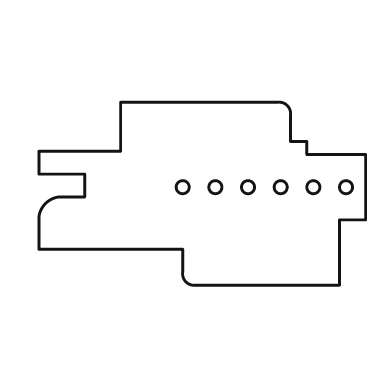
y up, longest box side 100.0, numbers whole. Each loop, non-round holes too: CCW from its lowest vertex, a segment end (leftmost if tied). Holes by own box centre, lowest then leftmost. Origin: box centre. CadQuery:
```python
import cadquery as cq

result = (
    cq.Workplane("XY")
    .moveTo(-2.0, -28.0)
    .lineTo(42.0, -28.0)
    .lineTo(42.0, -8.0)
    .lineTo(50.0, -8.0)
    .lineTo(50.0, 12.0)
    .lineTo(32.0, 12.0)
    .lineTo(32.0, 16.0)
    .lineTo(27.0, 16.0)
    .lineTo(27.0, 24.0)
    .threePointArc((26.0, 27.0), (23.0, 28.0))
    .lineTo(-25.0, 28.0)
    .lineTo(-25.0, 13.0)
    .lineTo(-50.0, 13.0)
    .lineTo(-50.0, 6.0)
    .lineTo(-36.0, 6.0)
    .lineTo(-36.0, -1.0)
    .lineTo(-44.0, -1.0)
    .threePointArc((-48.0, -3.0), (-50.0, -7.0))
    .lineTo(-50.0, -17.0)
    .lineTo(-6.0, -17.0)
    .lineTo(-6.0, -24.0)
    .threePointArc((-5.0, -27.0), (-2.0, -28.0))
    .close()
    .moveTo(-6.0, 2.0)
    .circle(2.0)
    .moveTo(4.0, 2.0)
    .circle(2.0)
    .moveTo(14.0, 2.0)
    .circle(2.0)
    .moveTo(24.0, 2.0)
    .circle(2.0)
    .moveTo(34.0, 2.0)
    .circle(2.0)
    .moveTo(44.0, 2.0)
    .circle(2.0)
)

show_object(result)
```